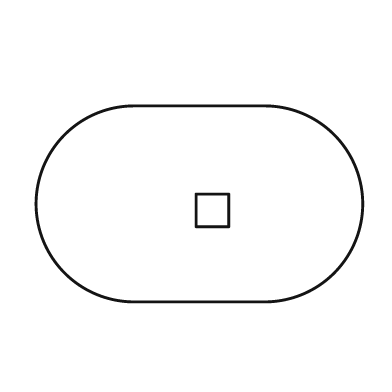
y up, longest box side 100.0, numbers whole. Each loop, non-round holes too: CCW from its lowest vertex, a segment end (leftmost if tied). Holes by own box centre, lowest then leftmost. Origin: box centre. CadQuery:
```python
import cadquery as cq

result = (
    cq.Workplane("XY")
    .moveTo(-20.0, -30.0)
    .lineTo(20.0, -30.0)
    .threePointArc((50.0, 0.0), (20.0, 30.0))
    .lineTo(-20.0, 30.0)
    .threePointArc((-50.0, 0.0), (-20.0, -30.0))
    .close()
    .moveTo(-1.0, -7.0)
    .lineTo(9.0, -7.0)
    .lineTo(9.0, 3.0)
    .lineTo(-1.0, 3.0)
    .close()
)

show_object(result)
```